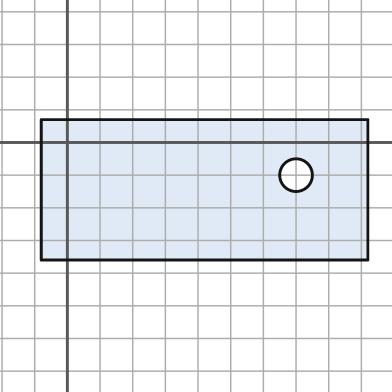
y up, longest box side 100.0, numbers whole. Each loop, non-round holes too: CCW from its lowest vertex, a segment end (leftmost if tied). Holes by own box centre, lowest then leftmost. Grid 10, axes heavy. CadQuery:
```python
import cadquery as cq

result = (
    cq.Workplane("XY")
    .moveTo(-8.0, -36.0)
    .lineTo(92.0, -36.0)
    .lineTo(92.0, 7.0)
    .lineTo(-8.0, 7.0)
    .close()
    .moveTo(70.0, -10.0)
    .circle(5.0)
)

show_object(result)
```